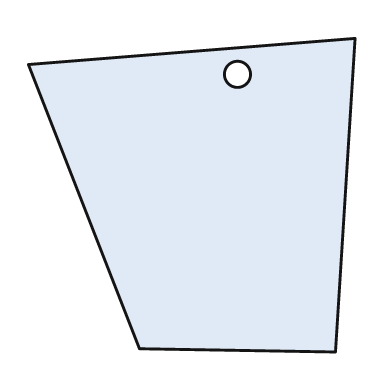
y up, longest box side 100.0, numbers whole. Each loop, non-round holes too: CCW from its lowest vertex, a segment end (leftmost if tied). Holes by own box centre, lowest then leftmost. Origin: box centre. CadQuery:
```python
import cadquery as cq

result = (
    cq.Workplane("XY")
    .moveTo(44.0, -48.0)
    .lineTo(50.0, 48.0)
    .lineTo(-50.0, 40.0)
    .lineTo(-16.0, -47.0)
    .close()
    .moveTo(14.0, 37.0)
    .circle(4.0)
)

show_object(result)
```